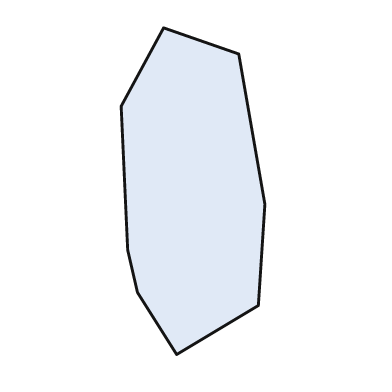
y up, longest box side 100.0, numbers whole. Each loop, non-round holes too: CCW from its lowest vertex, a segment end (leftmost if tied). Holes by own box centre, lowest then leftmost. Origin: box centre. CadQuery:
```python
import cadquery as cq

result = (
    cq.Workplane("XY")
    .moveTo(-5.0, -50.0)
    .lineTo(20.0, -35.0)
    .lineTo(22.0, -4.0)
    .lineTo(14.0, 42.0)
    .lineTo(-9.0, 50.0)
    .lineTo(-22.0, 26.0)
    .lineTo(-20.0, -18.0)
    .lineTo(-17.0, -31.0)
    .close()
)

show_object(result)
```